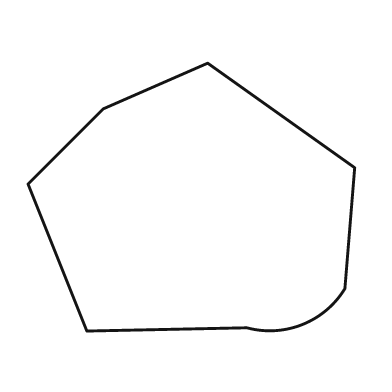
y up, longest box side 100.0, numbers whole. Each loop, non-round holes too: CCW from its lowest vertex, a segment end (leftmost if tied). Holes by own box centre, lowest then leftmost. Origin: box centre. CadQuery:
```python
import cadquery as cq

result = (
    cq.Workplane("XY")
    .moveTo(-32.0, -41.0)
    .lineTo(17.0, -40.0)
    .threePointArc((34.0, -39.0), (47.0, -28.0))
    .lineTo(50.0, 9.0)
    .lineTo(5.0, 41.0)
    .lineTo(-27.0, 27.0)
    .lineTo(-50.0, 4.0)
    .close()
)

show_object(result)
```